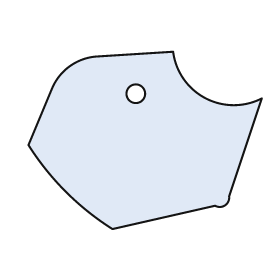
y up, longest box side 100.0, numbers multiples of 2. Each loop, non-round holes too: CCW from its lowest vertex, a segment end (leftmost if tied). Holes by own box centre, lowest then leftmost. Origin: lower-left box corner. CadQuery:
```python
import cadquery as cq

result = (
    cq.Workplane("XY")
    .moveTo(36.0, 0.0)
    .lineTo(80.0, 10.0)
    .threePointArc((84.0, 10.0), (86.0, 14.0))
    .lineTo(100.0, 56.0)
    .threePointArc((76.0, 56.0), (62.0, 76.0))
    .lineTo(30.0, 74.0)
    .threePointArc((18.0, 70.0), (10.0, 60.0))
    .lineTo(0.0, 36.0)
    .threePointArc((16.0, 16.0), (36.0, 0.0))
    .close()
    .moveTo(46.0, 58.0)
    .circle(4.0)
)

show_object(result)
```